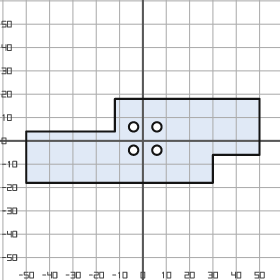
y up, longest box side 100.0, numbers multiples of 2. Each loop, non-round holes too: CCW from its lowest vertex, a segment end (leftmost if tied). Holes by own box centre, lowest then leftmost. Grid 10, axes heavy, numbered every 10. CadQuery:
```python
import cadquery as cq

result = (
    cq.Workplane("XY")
    .moveTo(-50.0, -18.0)
    .lineTo(30.0, -18.0)
    .lineTo(30.0, -6.0)
    .lineTo(50.0, -6.0)
    .lineTo(50.0, 18.0)
    .lineTo(-12.0, 18.0)
    .lineTo(-12.0, 4.0)
    .lineTo(-50.0, 4.0)
    .close()
    .moveTo(-4.0, -4.0)
    .circle(2.0)
    .moveTo(6.0, -4.0)
    .circle(2.0)
    .moveTo(-4.0, 6.0)
    .circle(2.0)
    .moveTo(6.0, 6.0)
    .circle(2.0)
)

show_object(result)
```